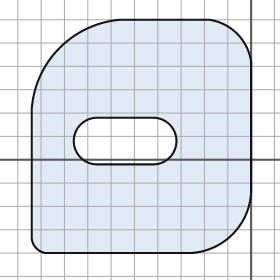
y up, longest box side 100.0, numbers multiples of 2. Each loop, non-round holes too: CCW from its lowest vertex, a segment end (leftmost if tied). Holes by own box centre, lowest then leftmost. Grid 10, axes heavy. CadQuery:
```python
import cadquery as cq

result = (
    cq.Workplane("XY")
    .moveTo(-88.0, -40.0)
    .lineTo(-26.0, -40.0)
    .threePointArc((-8.0, -32.0), (0.0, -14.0))
    .lineTo(0.0, 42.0)
    .threePointArc((-6.0, 54.0), (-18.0, 60.0))
    .lineTo(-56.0, 60.0)
    .threePointArc((-82.0, 48.0), (-94.0, 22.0))
    .lineTo(-94.0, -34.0)
    .threePointArc((-92.0, -38.0), (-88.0, -40.0))
    .close()
    .moveTo(-66.0, -2.0)
    .lineTo(-42.0, -2.0)
    .threePointArc((-32.0, 8.0), (-42.0, 18.0))
    .lineTo(-66.0, 18.0)
    .threePointArc((-76.0, 8.0), (-66.0, -2.0))
    .close()
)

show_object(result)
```